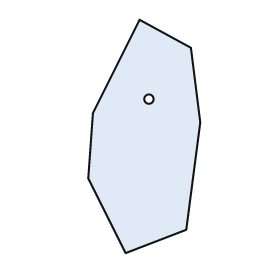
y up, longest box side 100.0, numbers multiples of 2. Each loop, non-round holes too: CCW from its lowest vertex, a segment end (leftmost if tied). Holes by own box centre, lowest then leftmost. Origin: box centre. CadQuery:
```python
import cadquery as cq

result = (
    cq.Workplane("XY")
    .moveTo(-8.0, -50.0)
    .lineTo(18.0, -40.0)
    .lineTo(24.0, 6.0)
    .lineTo(20.0, 38.0)
    .lineTo(-2.0, 50.0)
    .lineTo(-22.0, 10.0)
    .lineTo(-24.0, -18.0)
    .close()
    .moveTo(2.0, 16.0)
    .circle(2.0)
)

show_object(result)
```